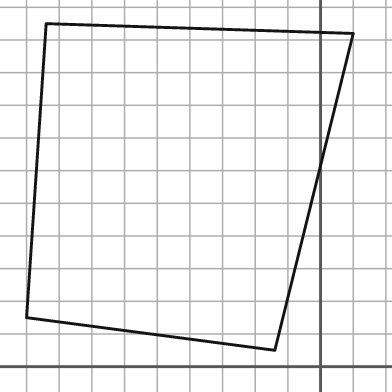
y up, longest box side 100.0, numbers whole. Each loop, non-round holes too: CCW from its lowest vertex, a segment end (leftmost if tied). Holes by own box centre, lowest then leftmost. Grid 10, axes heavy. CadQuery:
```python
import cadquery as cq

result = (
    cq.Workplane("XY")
    .moveTo(-14.0, 5.0)
    .lineTo(10.0, 102.0)
    .lineTo(-84.0, 105.0)
    .lineTo(-90.0, 15.0)
    .close()
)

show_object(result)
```